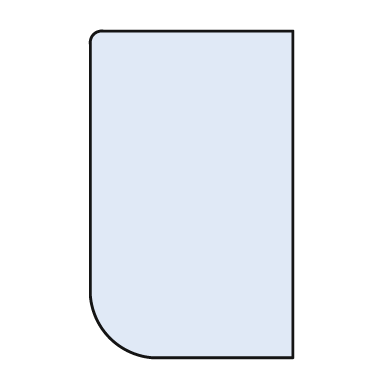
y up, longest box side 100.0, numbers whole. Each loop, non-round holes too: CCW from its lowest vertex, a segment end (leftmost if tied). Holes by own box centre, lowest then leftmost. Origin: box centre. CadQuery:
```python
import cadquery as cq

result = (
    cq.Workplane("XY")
    .moveTo(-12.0, -50.0)
    .lineTo(31.0, -50.0)
    .lineTo(31.0, 50.0)
    .lineTo(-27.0, 50.0)
    .threePointArc((-30.0, 49.0), (-31.0, 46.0))
    .lineTo(-31.0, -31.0)
    .threePointArc((-25.0, -44.0), (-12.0, -50.0))
    .close()
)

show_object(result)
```